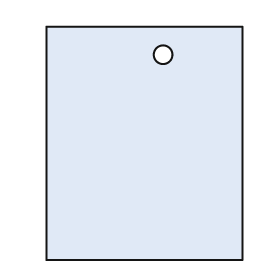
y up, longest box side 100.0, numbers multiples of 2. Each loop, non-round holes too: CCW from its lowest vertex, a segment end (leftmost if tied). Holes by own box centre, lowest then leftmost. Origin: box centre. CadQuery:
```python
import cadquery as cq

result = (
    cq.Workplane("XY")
    .moveTo(-42.0, -50.0)
    .lineTo(42.0, -50.0)
    .lineTo(42.0, 50.0)
    .lineTo(-42.0, 50.0)
    .close()
    .moveTo(8.0, 38.0)
    .circle(4.0)
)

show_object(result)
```